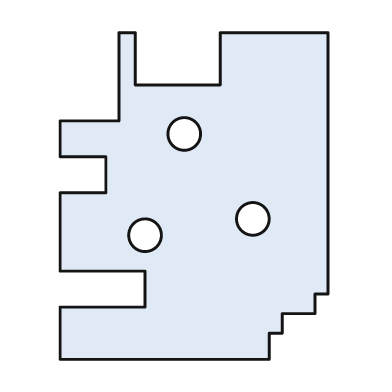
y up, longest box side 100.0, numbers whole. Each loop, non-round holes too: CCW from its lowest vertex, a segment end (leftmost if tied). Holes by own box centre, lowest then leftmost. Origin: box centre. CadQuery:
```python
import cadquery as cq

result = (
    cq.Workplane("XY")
    .moveTo(-41.0, -50.0)
    .lineTo(23.0, -50.0)
    .lineTo(23.0, -42.0)
    .lineTo(27.0, -42.0)
    .lineTo(27.0, -36.0)
    .lineTo(37.0, -36.0)
    .lineTo(37.0, -30.0)
    .lineTo(41.0, -30.0)
    .lineTo(41.0, 50.0)
    .lineTo(8.0, 50.0)
    .lineTo(8.0, 34.0)
    .lineTo(-18.0, 34.0)
    .lineTo(-18.0, 50.0)
    .lineTo(-23.0, 50.0)
    .lineTo(-23.0, 23.0)
    .lineTo(-41.0, 23.0)
    .lineTo(-41.0, 12.0)
    .lineTo(-27.0, 12.0)
    .lineTo(-27.0, 1.0)
    .lineTo(-41.0, 1.0)
    .lineTo(-41.0, -23.0)
    .lineTo(-15.0, -23.0)
    .lineTo(-15.0, -34.0)
    .lineTo(-41.0, -34.0)
    .close()
    .moveTo(-15.0, -12.0)
    .circle(5.0)
    .moveTo(18.0, -7.0)
    .circle(5.0)
    .moveTo(-3.0, 19.0)
    .circle(5.0)
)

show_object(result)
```